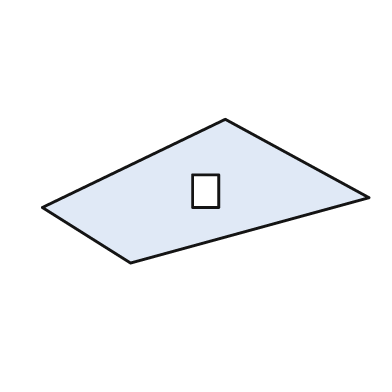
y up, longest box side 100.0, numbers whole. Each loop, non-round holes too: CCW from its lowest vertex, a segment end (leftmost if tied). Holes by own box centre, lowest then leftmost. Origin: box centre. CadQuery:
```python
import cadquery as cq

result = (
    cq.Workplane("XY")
    .moveTo(-23.0, -22.0)
    .lineTo(50.0, -2.0)
    .lineTo(6.0, 22.0)
    .lineTo(-50.0, -5.0)
    .close()
    .moveTo(-4.0, -5.0)
    .lineTo(4.0, -5.0)
    .lineTo(4.0, 5.0)
    .lineTo(-4.0, 5.0)
    .close()
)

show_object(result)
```